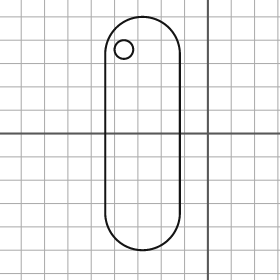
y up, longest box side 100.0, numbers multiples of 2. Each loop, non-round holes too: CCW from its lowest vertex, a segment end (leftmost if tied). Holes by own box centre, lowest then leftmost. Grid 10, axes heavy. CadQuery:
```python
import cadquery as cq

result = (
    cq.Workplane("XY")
    .moveTo(-44.0, -34.0)
    .threePointArc((-28.0, -50.0), (-12.0, -34.0))
    .lineTo(-12.0, 34.0)
    .threePointArc((-28.0, 50.0), (-44.0, 34.0))
    .close()
    .moveTo(-36.0, 36.0)
    .circle(4.0)
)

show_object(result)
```